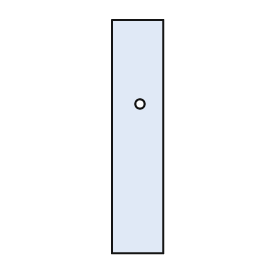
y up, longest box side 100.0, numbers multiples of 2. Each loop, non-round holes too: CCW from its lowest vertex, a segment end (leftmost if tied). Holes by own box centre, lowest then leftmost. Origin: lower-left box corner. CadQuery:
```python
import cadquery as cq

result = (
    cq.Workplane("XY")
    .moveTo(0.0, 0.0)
    .lineTo(22.0, 0.0)
    .lineTo(22.0, 100.0)
    .lineTo(0.0, 100.0)
    .close()
    .moveTo(12.0, 64.0)
    .circle(2.0)
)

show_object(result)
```